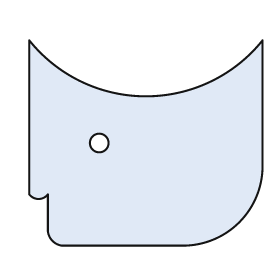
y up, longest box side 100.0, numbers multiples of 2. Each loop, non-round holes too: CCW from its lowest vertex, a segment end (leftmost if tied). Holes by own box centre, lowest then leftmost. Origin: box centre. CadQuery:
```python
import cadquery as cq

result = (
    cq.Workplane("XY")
    .moveTo(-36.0, -44.0)
    .lineTo(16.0, -44.0)
    .threePointArc((40.0, -34.0), (50.0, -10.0))
    .lineTo(50.0, 44.0)
    .threePointArc((0.0, 20.0), (-50.0, 44.0))
    .lineTo(-50.0, -22.0)
    .threePointArc((-46.0, -24.0), (-42.0, -22.0))
    .lineTo(-42.0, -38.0)
    .threePointArc((-40.0, -42.0), (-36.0, -44.0))
    .close()
    .moveTo(-20.0, 0.0)
    .circle(4.0)
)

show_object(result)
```